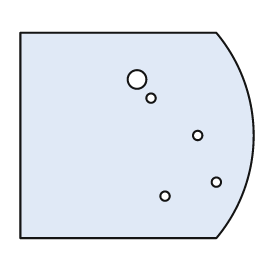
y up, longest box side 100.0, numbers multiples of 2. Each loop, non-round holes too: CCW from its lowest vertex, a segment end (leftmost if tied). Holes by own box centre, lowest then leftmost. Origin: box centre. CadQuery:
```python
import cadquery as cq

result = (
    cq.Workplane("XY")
    .moveTo(-50.0, -44.0)
    .lineTo(34.0, -44.0)
    .threePointArc((50.0, 0.0), (34.0, 44.0))
    .lineTo(-50.0, 44.0)
    .close()
    .moveTo(12.0, -26.0)
    .circle(2.0)
    .moveTo(34.0, -20.0)
    .circle(2.0)
    .moveTo(26.0, 0.0)
    .circle(2.0)
    .moveTo(6.0, 16.0)
    .circle(2.0)
    .moveTo(0.0, 24.0)
    .circle(4.0)
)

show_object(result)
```